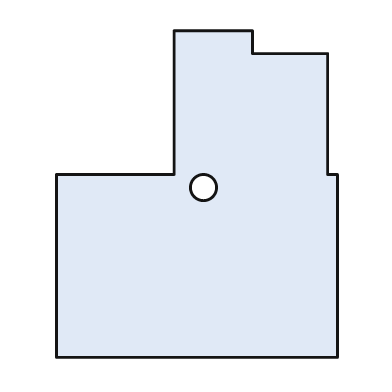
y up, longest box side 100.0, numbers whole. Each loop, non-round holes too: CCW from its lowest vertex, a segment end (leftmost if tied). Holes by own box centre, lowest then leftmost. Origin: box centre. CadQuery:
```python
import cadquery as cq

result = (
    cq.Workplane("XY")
    .moveTo(-43.0, -50.0)
    .lineTo(43.0, -50.0)
    .lineTo(43.0, 6.0)
    .lineTo(40.0, 6.0)
    .lineTo(40.0, 43.0)
    .lineTo(17.0, 43.0)
    .lineTo(17.0, 50.0)
    .lineTo(-7.0, 50.0)
    .lineTo(-7.0, 6.0)
    .lineTo(-43.0, 6.0)
    .close()
    .moveTo(2.0, 2.0)
    .circle(4.0)
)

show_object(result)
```